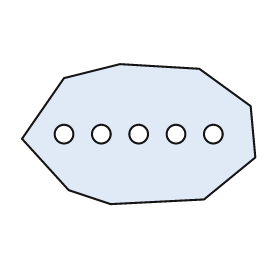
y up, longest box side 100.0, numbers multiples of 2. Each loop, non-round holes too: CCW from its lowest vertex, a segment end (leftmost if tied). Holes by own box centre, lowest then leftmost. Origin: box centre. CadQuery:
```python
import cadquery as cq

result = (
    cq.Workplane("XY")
    .moveTo(-12.0, -30.0)
    .lineTo(28.0, -28.0)
    .lineTo(50.0, -10.0)
    .lineTo(48.0, 12.0)
    .lineTo(26.0, 28.0)
    .lineTo(-8.0, 30.0)
    .lineTo(-32.0, 24.0)
    .lineTo(-50.0, -2.0)
    .lineTo(-30.0, -24.0)
    .close()
    .moveTo(-32.0, 0.0)
    .circle(4.0)
    .moveTo(-16.0, 0.0)
    .circle(4.0)
    .moveTo(0.0, 0.0)
    .circle(4.0)
    .moveTo(16.0, 0.0)
    .circle(4.0)
    .moveTo(32.0, 0.0)
    .circle(4.0)
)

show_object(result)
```